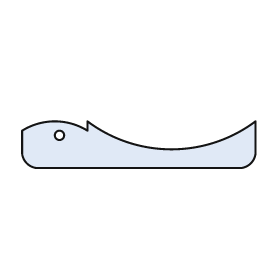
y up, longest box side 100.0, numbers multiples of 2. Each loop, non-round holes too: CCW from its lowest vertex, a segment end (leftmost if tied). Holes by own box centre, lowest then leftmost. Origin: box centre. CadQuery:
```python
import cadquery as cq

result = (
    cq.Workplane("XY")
    .moveTo(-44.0, -10.0)
    .lineTo(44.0, -10.0)
    .threePointArc((48.0, -8.0), (50.0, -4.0))
    .lineTo(50.0, 10.0)
    .threePointArc((14.0, -2.0), (-22.0, 10.0))
    .lineTo(-22.0, 6.0)
    .threePointArc((-36.0, 10.0), (-50.0, 6.0))
    .lineTo(-50.0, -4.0)
    .threePointArc((-48.0, -8.0), (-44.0, -10.0))
    .close()
    .moveTo(-34.0, 4.0)
    .circle(2.0)
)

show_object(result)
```